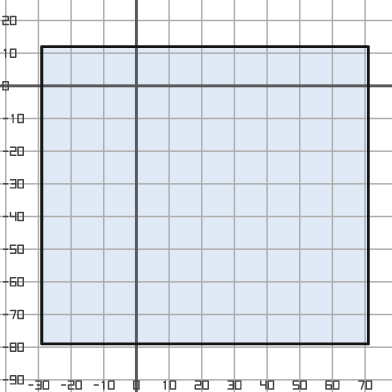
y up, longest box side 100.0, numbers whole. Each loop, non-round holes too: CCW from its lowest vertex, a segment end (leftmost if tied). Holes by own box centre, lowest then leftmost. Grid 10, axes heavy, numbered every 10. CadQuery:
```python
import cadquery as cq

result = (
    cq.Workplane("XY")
    .moveTo(-29.0, -79.0)
    .lineTo(71.0, -79.0)
    .lineTo(71.0, 12.0)
    .lineTo(-29.0, 12.0)
    .close()
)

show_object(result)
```